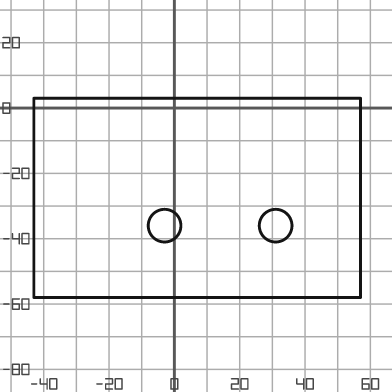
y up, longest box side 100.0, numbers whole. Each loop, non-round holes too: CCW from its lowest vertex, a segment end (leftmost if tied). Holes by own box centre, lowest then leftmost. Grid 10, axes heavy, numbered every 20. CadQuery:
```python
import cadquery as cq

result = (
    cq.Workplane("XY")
    .moveTo(-43.0, -58.0)
    .lineTo(57.0, -58.0)
    .lineTo(57.0, 3.0)
    .lineTo(-43.0, 3.0)
    .close()
    .moveTo(-3.0, -36.0)
    .circle(5.0)
    .moveTo(31.0, -36.0)
    .circle(5.0)
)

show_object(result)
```